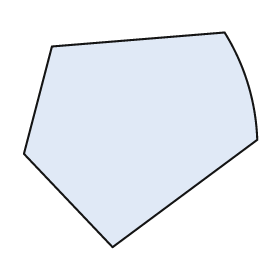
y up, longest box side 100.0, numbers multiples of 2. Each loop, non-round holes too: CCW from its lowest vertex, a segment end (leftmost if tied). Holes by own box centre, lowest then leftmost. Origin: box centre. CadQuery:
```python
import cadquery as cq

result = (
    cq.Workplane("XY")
    .moveTo(-12.0, -46.0)
    .lineTo(50.0, 0.0)
    .threePointArc((46.0, 24.0), (36.0, 46.0))
    .lineTo(-38.0, 40.0)
    .lineTo(-50.0, -6.0)
    .close()
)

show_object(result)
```